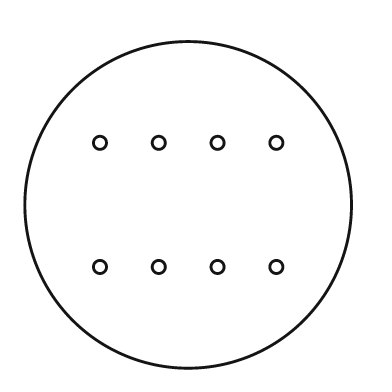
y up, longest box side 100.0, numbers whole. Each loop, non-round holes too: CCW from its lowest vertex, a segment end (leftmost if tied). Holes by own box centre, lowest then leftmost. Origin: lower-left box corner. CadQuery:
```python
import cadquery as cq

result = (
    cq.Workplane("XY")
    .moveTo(50.0, 50.0)
    .circle(50.0)
    .moveTo(23.0, 31.0)
    .circle(2.0)
    .moveTo(41.0, 31.0)
    .circle(2.0)
    .moveTo(59.0, 31.0)
    .circle(2.0)
    .moveTo(77.0, 31.0)
    .circle(2.0)
    .moveTo(23.0, 69.0)
    .circle(2.0)
    .moveTo(41.0, 69.0)
    .circle(2.0)
    .moveTo(59.0, 69.0)
    .circle(2.0)
    .moveTo(77.0, 69.0)
    .circle(2.0)
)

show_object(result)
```